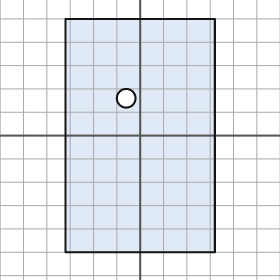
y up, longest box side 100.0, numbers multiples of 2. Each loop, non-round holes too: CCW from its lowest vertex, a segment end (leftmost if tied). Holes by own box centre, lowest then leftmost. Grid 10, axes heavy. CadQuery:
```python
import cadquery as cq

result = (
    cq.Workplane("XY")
    .moveTo(-32.0, -50.0)
    .lineTo(32.0, -50.0)
    .lineTo(32.0, 50.0)
    .lineTo(-32.0, 50.0)
    .close()
    .moveTo(-6.0, 16.0)
    .circle(4.0)
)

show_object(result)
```